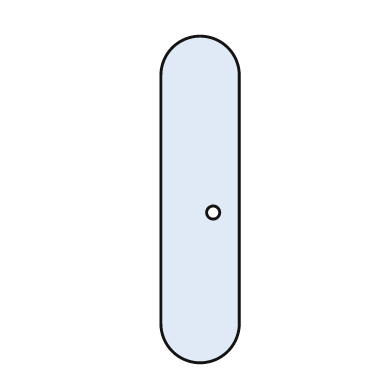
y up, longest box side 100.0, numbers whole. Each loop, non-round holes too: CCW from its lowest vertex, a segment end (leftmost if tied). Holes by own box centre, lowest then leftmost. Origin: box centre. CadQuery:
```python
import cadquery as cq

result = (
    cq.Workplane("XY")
    .moveTo(-12.0, -38.0)
    .threePointArc((0.0, -50.0), (12.0, -38.0))
    .lineTo(12.0, 38.0)
    .threePointArc((0.0, 50.0), (-12.0, 38.0))
    .close()
    .moveTo(4.0, -4.0)
    .circle(2.0)
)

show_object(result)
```